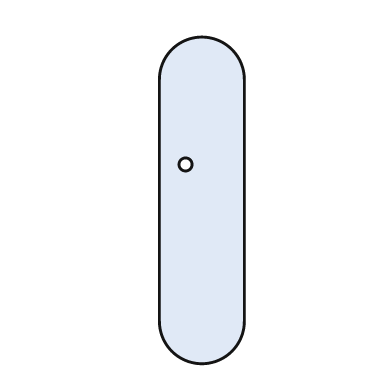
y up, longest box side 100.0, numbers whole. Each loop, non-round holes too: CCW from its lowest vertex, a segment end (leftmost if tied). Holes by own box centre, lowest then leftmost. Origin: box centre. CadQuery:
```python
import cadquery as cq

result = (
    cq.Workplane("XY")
    .moveTo(-13.0, -37.0)
    .threePointArc((0.0, -50.0), (13.0, -37.0))
    .lineTo(13.0, 37.0)
    .threePointArc((0.0, 50.0), (-13.0, 37.0))
    .close()
    .moveTo(-5.0, 11.0)
    .circle(2.0)
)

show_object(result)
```